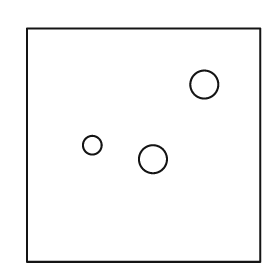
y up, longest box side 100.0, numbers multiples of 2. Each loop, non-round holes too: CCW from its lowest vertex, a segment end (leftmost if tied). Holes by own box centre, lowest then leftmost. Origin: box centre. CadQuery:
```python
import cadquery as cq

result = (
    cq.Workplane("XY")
    .moveTo(-50.0, -50.0)
    .lineTo(50.0, -50.0)
    .lineTo(50.0, 50.0)
    .lineTo(-50.0, 50.0)
    .close()
    .moveTo(4.0, -6.0)
    .circle(6.0)
    .moveTo(-22.0, 0.0)
    .circle(4.0)
    .moveTo(26.0, 26.0)
    .circle(6.0)
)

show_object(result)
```